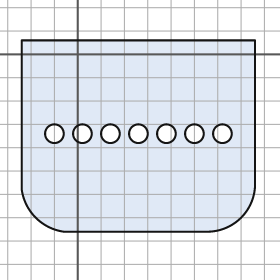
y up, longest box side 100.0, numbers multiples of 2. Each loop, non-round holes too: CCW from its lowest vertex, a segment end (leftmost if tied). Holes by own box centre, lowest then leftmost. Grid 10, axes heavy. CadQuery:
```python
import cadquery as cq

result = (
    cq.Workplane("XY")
    .moveTo(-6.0, -76.0)
    .lineTo(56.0, -76.0)
    .threePointArc((70.0, -70.0), (76.0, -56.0))
    .lineTo(76.0, 6.0)
    .lineTo(-24.0, 6.0)
    .lineTo(-24.0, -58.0)
    .threePointArc((-18.0, -70.0), (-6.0, -76.0))
    .close()
    .moveTo(-10.0, -34.0)
    .circle(4.0)
    .moveTo(2.0, -34.0)
    .circle(4.0)
    .moveTo(14.0, -34.0)
    .circle(4.0)
    .moveTo(26.0, -34.0)
    .circle(4.0)
    .moveTo(38.0, -34.0)
    .circle(4.0)
    .moveTo(50.0, -34.0)
    .circle(4.0)
    .moveTo(62.0, -34.0)
    .circle(4.0)
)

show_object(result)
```